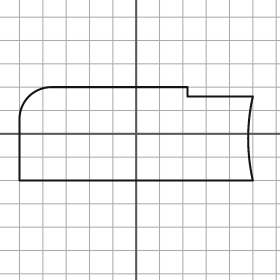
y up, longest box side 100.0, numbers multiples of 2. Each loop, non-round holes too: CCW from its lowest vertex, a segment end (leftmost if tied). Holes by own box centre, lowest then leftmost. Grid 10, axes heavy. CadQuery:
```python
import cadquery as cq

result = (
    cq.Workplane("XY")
    .moveTo(-50.0, -20.0)
    .lineTo(50.0, -20.0)
    .threePointArc((48.0, -2.0), (50.0, 16.0))
    .lineTo(22.0, 16.0)
    .lineTo(22.0, 20.0)
    .lineTo(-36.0, 20.0)
    .threePointArc((-46.0, 16.0), (-50.0, 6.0))
    .close()
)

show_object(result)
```